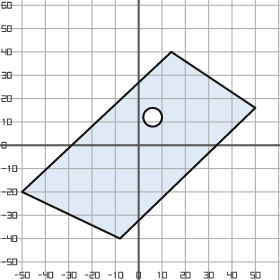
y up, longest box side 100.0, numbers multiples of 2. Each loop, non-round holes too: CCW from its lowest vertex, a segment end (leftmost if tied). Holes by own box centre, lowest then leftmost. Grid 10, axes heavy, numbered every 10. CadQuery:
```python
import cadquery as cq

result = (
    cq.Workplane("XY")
    .moveTo(-8.0, -40.0)
    .lineTo(50.0, 16.0)
    .lineTo(14.0, 40.0)
    .lineTo(-50.0, -20.0)
    .close()
    .moveTo(6.0, 12.0)
    .circle(4.0)
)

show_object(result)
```